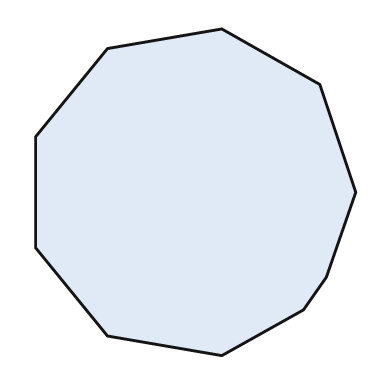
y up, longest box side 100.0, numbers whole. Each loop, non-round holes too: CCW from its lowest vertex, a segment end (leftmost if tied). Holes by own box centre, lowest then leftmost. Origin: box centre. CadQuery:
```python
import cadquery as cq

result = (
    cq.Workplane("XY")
    .moveTo(8.0, -50.0)
    .lineTo(33.0, -36.0)
    .lineTo(40.0, -26.0)
    .lineTo(49.0, 0.0)
    .lineTo(38.0, 33.0)
    .lineTo(8.0, 50.0)
    .lineTo(-27.0, 44.0)
    .lineTo(-49.0, 17.0)
    .lineTo(-49.0, -17.0)
    .lineTo(-27.0, -44.0)
    .close()
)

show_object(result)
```